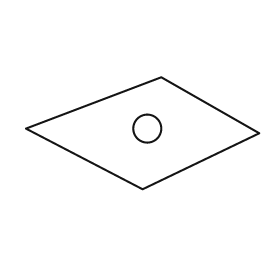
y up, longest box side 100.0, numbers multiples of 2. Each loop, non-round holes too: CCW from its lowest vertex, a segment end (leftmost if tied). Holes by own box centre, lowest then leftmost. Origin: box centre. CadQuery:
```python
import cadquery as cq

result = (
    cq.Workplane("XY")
    .moveTo(0.0, -24.0)
    .lineTo(50.0, 0.0)
    .lineTo(8.0, 24.0)
    .lineTo(-50.0, 2.0)
    .close()
    .moveTo(2.0, 2.0)
    .circle(6.0)
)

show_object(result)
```